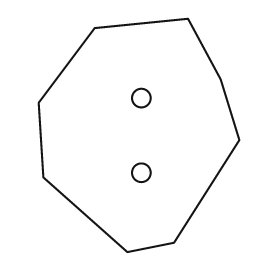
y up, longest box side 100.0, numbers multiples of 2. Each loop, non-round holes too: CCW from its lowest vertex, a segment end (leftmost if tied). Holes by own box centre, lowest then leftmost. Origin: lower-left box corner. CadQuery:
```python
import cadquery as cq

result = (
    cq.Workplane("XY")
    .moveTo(38.0, 0.0)
    .lineTo(58.0, 4.0)
    .lineTo(86.0, 48.0)
    .lineTo(78.0, 74.0)
    .lineTo(64.0, 100.0)
    .lineTo(24.0, 96.0)
    .lineTo(0.0, 64.0)
    .lineTo(2.0, 32.0)
    .close()
    .moveTo(44.0, 34.0)
    .circle(4.0)
    .moveTo(44.0, 66.0)
    .circle(4.0)
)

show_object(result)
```